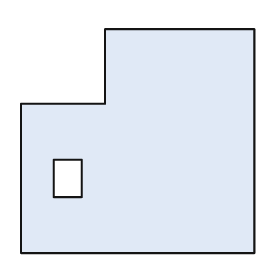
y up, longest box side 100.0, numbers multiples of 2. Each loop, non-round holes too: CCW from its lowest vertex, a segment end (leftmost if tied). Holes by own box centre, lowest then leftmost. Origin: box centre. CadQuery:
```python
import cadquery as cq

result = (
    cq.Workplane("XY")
    .moveTo(-50.0, -48.0)
    .lineTo(50.0, -48.0)
    .lineTo(50.0, 48.0)
    .lineTo(-14.0, 48.0)
    .lineTo(-14.0, 16.0)
    .lineTo(-50.0, 16.0)
    .close()
    .moveTo(-36.0, -24.0)
    .lineTo(-24.0, -24.0)
    .lineTo(-24.0, -8.0)
    .lineTo(-36.0, -8.0)
    .close()
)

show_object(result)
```